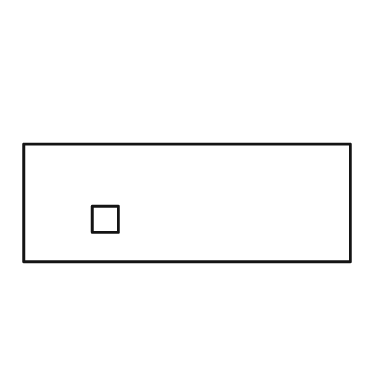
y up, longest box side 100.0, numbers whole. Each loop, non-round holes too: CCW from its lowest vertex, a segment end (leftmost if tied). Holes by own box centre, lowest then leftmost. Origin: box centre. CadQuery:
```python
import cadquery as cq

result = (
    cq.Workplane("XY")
    .moveTo(-50.0, -18.0)
    .lineTo(50.0, -18.0)
    .lineTo(50.0, 18.0)
    .lineTo(-50.0, 18.0)
    .close()
    .moveTo(-29.0, -9.0)
    .lineTo(-21.0, -9.0)
    .lineTo(-21.0, -1.0)
    .lineTo(-29.0, -1.0)
    .close()
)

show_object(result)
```